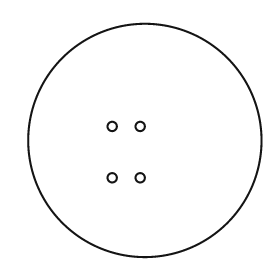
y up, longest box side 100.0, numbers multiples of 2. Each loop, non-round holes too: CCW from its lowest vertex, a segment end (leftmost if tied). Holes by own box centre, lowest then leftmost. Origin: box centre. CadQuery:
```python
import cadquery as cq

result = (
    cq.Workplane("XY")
    .moveTo(0.0, 0.0)
    .circle(50.0)
    .moveTo(-14.0, -16.0)
    .circle(2.0)
    .moveTo(-2.0, -16.0)
    .circle(2.0)
    .moveTo(-14.0, 6.0)
    .circle(2.0)
    .moveTo(-2.0, 6.0)
    .circle(2.0)
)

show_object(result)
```